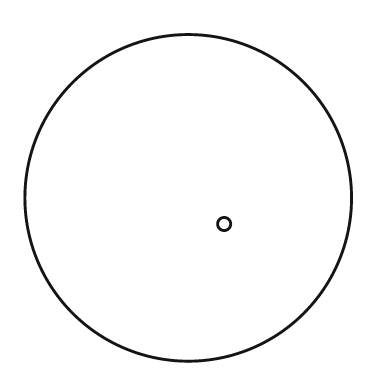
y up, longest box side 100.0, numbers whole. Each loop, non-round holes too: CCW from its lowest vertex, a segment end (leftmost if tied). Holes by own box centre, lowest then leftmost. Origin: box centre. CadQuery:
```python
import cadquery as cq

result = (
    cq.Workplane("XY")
    .moveTo(0.0, 0.0)
    .circle(50.0)
    .moveTo(11.0, -8.0)
    .circle(2.0)
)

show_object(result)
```